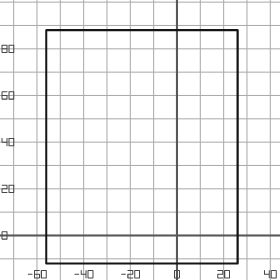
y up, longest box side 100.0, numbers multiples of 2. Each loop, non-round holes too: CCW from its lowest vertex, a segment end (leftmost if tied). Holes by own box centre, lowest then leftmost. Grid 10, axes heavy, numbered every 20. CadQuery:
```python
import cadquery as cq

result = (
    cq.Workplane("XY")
    .moveTo(-56.0, -12.0)
    .lineTo(26.0, -12.0)
    .lineTo(26.0, 88.0)
    .lineTo(-56.0, 88.0)
    .close()
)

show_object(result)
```